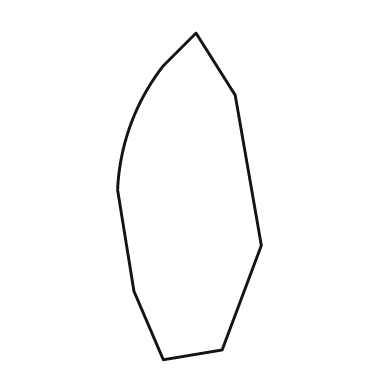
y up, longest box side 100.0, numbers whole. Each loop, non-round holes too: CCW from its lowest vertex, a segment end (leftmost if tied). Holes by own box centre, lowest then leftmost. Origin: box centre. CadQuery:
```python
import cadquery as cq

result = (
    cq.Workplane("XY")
    .moveTo(-8.0, -50.0)
    .lineTo(10.0, -47.0)
    .lineTo(22.0, -15.0)
    .lineTo(14.0, 31.0)
    .lineTo(2.0, 50.0)
    .lineTo(-8.0, 40.0)
    .threePointArc((-18.0, 22.0), (-22.0, 2.0))
    .lineTo(-17.0, -29.0)
    .close()
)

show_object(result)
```